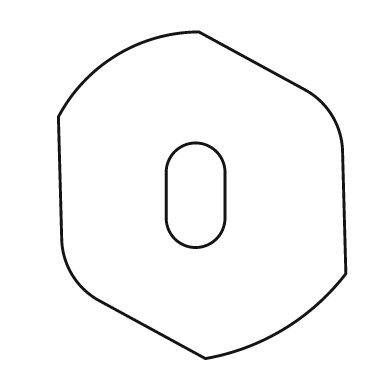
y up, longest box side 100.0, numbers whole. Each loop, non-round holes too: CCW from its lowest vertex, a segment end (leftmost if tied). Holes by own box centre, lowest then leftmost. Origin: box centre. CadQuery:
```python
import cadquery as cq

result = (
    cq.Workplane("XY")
    .moveTo(1.0, -50.0)
    .threePointArc((25.0, -41.0), (44.0, -24.0))
    .lineTo(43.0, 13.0)
    .threePointArc((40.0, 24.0), (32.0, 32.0))
    .lineTo(-1.0, 50.0)
    .threePointArc((-26.0, 43.0), (-44.0, 24.0))
    .lineTo(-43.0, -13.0)
    .threePointArc((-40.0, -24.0), (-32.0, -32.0))
    .close()
    .moveTo(-11.0, -7.0)
    .threePointArc((-2.0, -16.0), (7.0, -7.0))
    .lineTo(7.0, 7.0)
    .threePointArc((-2.0, 16.0), (-11.0, 7.0))
    .close()
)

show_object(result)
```